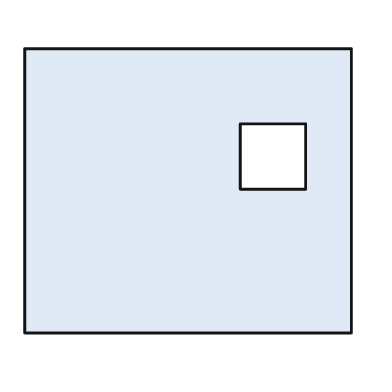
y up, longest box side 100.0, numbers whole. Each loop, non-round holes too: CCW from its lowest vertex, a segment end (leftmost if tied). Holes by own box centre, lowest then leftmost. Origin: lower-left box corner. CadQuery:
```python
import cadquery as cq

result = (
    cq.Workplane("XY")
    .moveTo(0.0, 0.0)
    .lineTo(100.0, 0.0)
    .lineTo(100.0, 87.0)
    .lineTo(0.0, 87.0)
    .close()
    .moveTo(66.0, 44.0)
    .lineTo(86.0, 44.0)
    .lineTo(86.0, 64.0)
    .lineTo(66.0, 64.0)
    .close()
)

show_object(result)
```